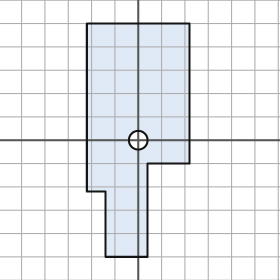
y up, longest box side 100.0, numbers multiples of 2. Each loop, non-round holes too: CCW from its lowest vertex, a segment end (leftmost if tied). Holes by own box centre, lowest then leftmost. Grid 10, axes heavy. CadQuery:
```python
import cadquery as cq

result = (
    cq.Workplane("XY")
    .moveTo(-14.0, -50.0)
    .lineTo(4.0, -50.0)
    .lineTo(4.0, -10.0)
    .lineTo(22.0, -10.0)
    .lineTo(22.0, 50.0)
    .lineTo(-22.0, 50.0)
    .lineTo(-22.0, -22.0)
    .lineTo(-14.0, -22.0)
    .close()
    .moveTo(0.0, 0.0)
    .circle(4.0)
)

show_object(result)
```